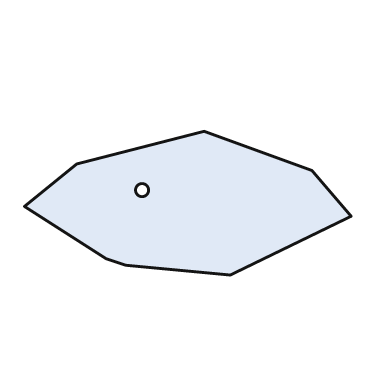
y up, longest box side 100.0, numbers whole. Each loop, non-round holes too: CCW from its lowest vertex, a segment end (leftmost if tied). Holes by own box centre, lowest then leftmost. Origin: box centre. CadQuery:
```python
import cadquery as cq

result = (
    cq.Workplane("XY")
    .moveTo(13.0, -22.0)
    .lineTo(50.0, -4.0)
    .lineTo(38.0, 10.0)
    .lineTo(5.0, 22.0)
    .lineTo(-34.0, 12.0)
    .lineTo(-50.0, -1.0)
    .lineTo(-25.0, -17.0)
    .lineTo(-19.0, -19.0)
    .close()
    .moveTo(-14.0, 4.0)
    .circle(2.0)
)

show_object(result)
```